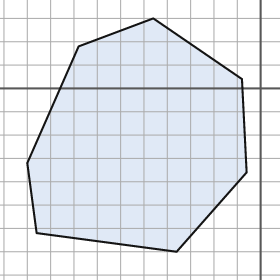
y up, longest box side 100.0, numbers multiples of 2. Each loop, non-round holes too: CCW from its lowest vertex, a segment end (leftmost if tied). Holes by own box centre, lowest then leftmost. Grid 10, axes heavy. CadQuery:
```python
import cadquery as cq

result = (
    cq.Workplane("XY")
    .moveTo(-36.0, -70.0)
    .lineTo(-6.0, -36.0)
    .lineTo(-8.0, 4.0)
    .lineTo(-46.0, 30.0)
    .lineTo(-78.0, 18.0)
    .lineTo(-100.0, -32.0)
    .lineTo(-96.0, -62.0)
    .close()
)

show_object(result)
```